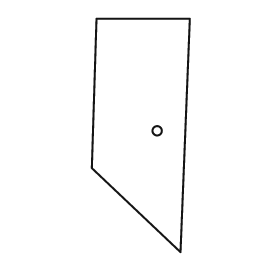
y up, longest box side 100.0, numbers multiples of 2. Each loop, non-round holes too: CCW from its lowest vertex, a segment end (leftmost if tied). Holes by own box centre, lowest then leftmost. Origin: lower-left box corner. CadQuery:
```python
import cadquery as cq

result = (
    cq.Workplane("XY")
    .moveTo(38.0, 0.0)
    .lineTo(42.0, 100.0)
    .lineTo(2.0, 100.0)
    .lineTo(0.0, 36.0)
    .close()
    .moveTo(28.0, 52.0)
    .circle(2.0)
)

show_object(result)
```